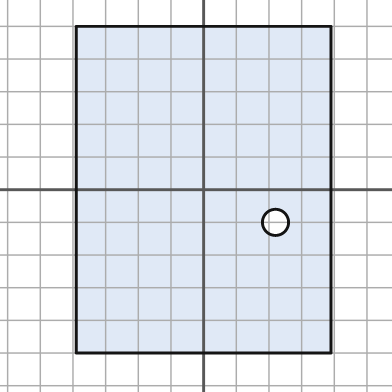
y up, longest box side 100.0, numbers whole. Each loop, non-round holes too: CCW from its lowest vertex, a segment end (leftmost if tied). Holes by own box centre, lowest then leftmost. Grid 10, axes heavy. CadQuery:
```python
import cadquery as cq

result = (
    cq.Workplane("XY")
    .moveTo(-39.0, -50.0)
    .lineTo(39.0, -50.0)
    .lineTo(39.0, 50.0)
    .lineTo(-39.0, 50.0)
    .close()
    .moveTo(22.0, -10.0)
    .circle(4.0)
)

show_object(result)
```